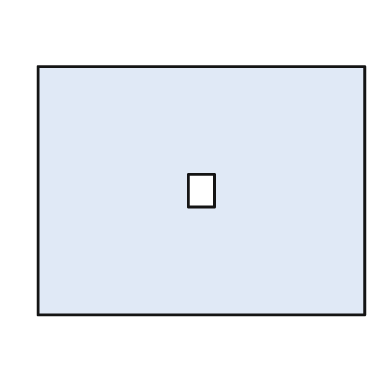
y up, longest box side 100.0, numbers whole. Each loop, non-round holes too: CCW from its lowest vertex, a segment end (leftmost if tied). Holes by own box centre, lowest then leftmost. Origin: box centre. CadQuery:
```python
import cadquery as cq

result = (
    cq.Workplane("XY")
    .moveTo(-50.0, -38.0)
    .lineTo(50.0, -38.0)
    .lineTo(50.0, 38.0)
    .lineTo(-50.0, 38.0)
    .close()
    .moveTo(-4.0, -5.0)
    .lineTo(4.0, -5.0)
    .lineTo(4.0, 5.0)
    .lineTo(-4.0, 5.0)
    .close()
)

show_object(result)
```